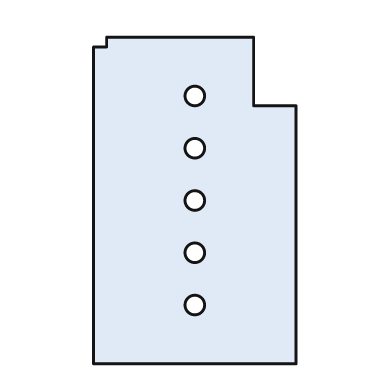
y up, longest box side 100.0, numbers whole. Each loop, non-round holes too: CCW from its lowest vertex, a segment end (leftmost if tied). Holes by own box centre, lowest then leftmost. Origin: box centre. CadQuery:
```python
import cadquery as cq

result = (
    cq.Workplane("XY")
    .moveTo(-31.0, -50.0)
    .lineTo(31.0, -50.0)
    .lineTo(31.0, 29.0)
    .lineTo(18.0, 29.0)
    .lineTo(18.0, 50.0)
    .lineTo(-27.0, 50.0)
    .lineTo(-27.0, 47.0)
    .lineTo(-31.0, 47.0)
    .close()
    .moveTo(0.0, -32.0)
    .circle(3.0)
    .moveTo(0.0, -16.0)
    .circle(3.0)
    .moveTo(0.0, 0.0)
    .circle(3.0)
    .moveTo(0.0, 16.0)
    .circle(3.0)
    .moveTo(0.0, 32.0)
    .circle(3.0)
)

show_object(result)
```